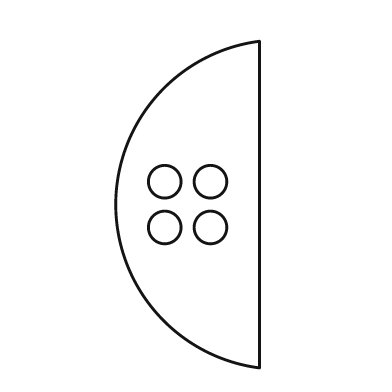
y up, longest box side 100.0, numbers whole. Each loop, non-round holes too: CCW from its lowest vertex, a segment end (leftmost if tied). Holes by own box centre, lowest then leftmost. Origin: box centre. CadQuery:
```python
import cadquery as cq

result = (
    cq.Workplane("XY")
    .moveTo(22.0, -50.0)
    .lineTo(22.0, 50.0)
    .threePointArc((-22.0, 0.0), (22.0, -50.0))
    .close()
    .moveTo(-7.0, -7.0)
    .circle(5.0)
    .moveTo(7.0, -7.0)
    .circle(5.0)
    .moveTo(-7.0, 7.0)
    .circle(5.0)
    .moveTo(7.0, 7.0)
    .circle(5.0)
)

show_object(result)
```